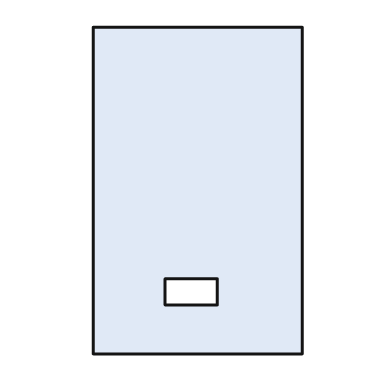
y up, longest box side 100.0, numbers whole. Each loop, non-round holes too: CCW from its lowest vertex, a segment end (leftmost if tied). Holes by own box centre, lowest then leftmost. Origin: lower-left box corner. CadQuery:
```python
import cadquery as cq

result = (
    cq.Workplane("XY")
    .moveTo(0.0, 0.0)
    .lineTo(64.0, 0.0)
    .lineTo(64.0, 100.0)
    .lineTo(0.0, 100.0)
    .close()
    .moveTo(22.0, 15.0)
    .lineTo(38.0, 15.0)
    .lineTo(38.0, 23.0)
    .lineTo(22.0, 23.0)
    .close()
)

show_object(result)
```